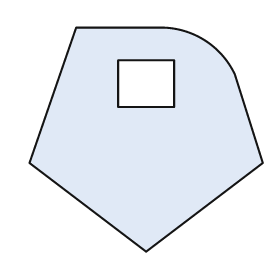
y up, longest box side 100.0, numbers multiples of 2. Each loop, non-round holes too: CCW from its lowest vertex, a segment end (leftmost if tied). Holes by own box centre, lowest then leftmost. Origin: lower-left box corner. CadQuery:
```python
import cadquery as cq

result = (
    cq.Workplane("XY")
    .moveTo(50.0, 0.0)
    .lineTo(100.0, 38.0)
    .lineTo(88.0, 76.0)
    .threePointArc((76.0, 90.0), (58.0, 96.0))
    .lineTo(20.0, 96.0)
    .lineTo(0.0, 38.0)
    .close()
    .moveTo(38.0, 62.0)
    .lineTo(62.0, 62.0)
    .lineTo(62.0, 82.0)
    .lineTo(38.0, 82.0)
    .close()
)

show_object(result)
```